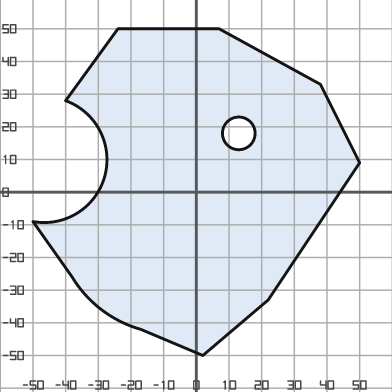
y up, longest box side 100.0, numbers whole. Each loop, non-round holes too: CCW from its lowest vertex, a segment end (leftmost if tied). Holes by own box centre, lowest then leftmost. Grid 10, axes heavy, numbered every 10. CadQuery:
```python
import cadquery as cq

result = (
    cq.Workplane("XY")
    .moveTo(2.0, -50.0)
    .lineTo(22.0, -33.0)
    .lineTo(50.0, 9.0)
    .lineTo(38.0, 33.0)
    .lineTo(7.0, 50.0)
    .lineTo(-24.0, 50.0)
    .lineTo(-40.0, 28.0)
    .threePointArc((-28.0, 5.0), (-50.0, -9.0))
    .lineTo(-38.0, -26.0)
    .threePointArc((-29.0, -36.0), (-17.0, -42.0))
    .close()
    .moveTo(13.0, 18.0)
    .circle(5.0)
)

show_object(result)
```